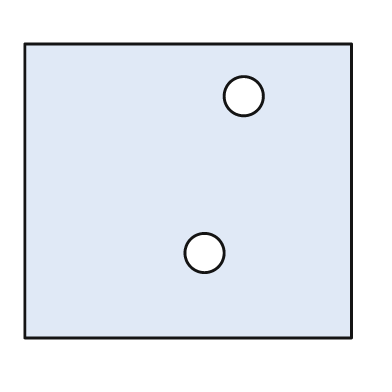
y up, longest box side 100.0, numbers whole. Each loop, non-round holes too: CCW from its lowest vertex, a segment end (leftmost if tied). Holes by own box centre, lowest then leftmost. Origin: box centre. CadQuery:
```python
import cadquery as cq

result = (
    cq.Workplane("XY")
    .moveTo(-50.0, -45.0)
    .lineTo(50.0, -45.0)
    .lineTo(50.0, 45.0)
    .lineTo(-50.0, 45.0)
    .close()
    .moveTo(5.0, -19.0)
    .circle(6.0)
    .moveTo(17.0, 29.0)
    .circle(6.0)
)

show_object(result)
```